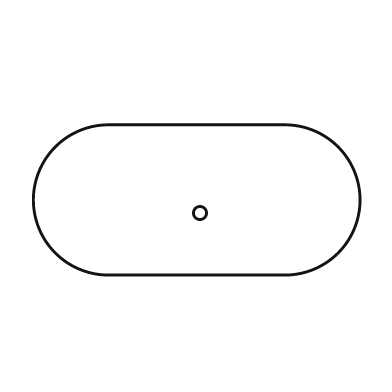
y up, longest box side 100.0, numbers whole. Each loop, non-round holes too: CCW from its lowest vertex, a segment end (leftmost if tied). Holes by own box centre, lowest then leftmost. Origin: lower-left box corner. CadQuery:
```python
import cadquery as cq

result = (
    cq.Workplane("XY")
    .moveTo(23.0, 0.0)
    .lineTo(77.0, 0.0)
    .threePointArc((100.0, 23.0), (77.0, 46.0))
    .lineTo(23.0, 46.0)
    .threePointArc((0.0, 23.0), (23.0, 0.0))
    .close()
    .moveTo(51.0, 19.0)
    .circle(2.0)
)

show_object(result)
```